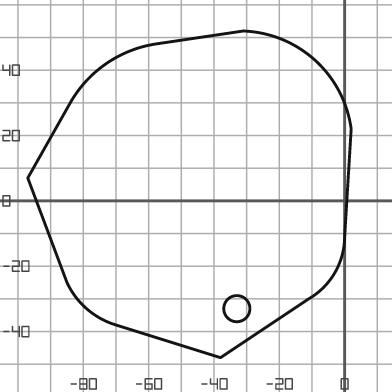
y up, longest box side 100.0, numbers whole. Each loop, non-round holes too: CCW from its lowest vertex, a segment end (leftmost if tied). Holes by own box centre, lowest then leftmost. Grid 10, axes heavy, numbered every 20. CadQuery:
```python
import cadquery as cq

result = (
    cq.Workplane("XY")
    .moveTo(-38.0, -48.0)
    .lineTo(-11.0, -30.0)
    .threePointArc((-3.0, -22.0), (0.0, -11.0))
    .lineTo(2.0, 22.0)
    .threePointArc((-9.0, 43.0), (-31.0, 52.0))
    .lineTo(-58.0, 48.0)
    .threePointArc((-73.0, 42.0), (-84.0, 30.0))
    .lineTo(-97.0, 7.0)
    .lineTo(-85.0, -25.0)
    .threePointArc((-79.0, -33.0), (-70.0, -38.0))
    .close()
    .moveTo(-33.0, -33.0)
    .circle(4.0)
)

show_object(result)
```